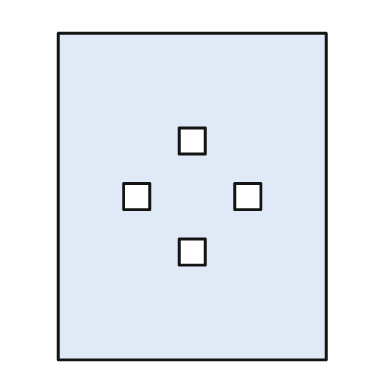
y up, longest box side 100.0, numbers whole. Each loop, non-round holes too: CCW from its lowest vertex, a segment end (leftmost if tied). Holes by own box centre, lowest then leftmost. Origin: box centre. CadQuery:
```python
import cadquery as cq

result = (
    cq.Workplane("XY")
    .moveTo(-41.0, -50.0)
    .lineTo(41.0, -50.0)
    .lineTo(41.0, 50.0)
    .lineTo(-41.0, 50.0)
    .close()
    .moveTo(-4.0, -21.0)
    .lineTo(4.0, -21.0)
    .lineTo(4.0, -13.0)
    .lineTo(-4.0, -13.0)
    .close()
    .moveTo(-21.0, -4.0)
    .lineTo(-13.0, -4.0)
    .lineTo(-13.0, 4.0)
    .lineTo(-21.0, 4.0)
    .close()
    .moveTo(13.0, -4.0)
    .lineTo(21.0, -4.0)
    .lineTo(21.0, 4.0)
    .lineTo(13.0, 4.0)
    .close()
    .moveTo(-4.0, 13.0)
    .lineTo(4.0, 13.0)
    .lineTo(4.0, 21.0)
    .lineTo(-4.0, 21.0)
    .close()
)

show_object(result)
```